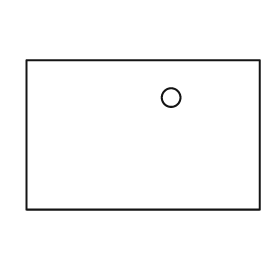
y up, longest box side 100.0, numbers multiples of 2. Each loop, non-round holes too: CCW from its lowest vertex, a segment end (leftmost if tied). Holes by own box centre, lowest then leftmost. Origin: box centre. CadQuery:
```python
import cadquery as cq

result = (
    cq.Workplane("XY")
    .moveTo(-50.0, -32.0)
    .lineTo(50.0, -32.0)
    .lineTo(50.0, 32.0)
    .lineTo(-50.0, 32.0)
    .close()
    .moveTo(12.0, 16.0)
    .circle(4.0)
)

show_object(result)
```